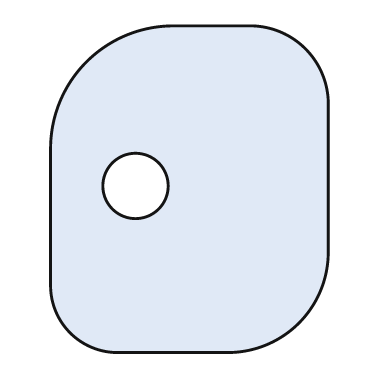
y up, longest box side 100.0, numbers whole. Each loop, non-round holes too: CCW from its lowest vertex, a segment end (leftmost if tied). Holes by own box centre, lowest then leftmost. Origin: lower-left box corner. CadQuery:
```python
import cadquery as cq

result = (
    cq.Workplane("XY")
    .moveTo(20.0, 0.0)
    .lineTo(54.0, 0.0)
    .threePointArc((76.0, 9.0), (85.0, 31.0))
    .lineTo(85.0, 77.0)
    .threePointArc((78.0, 93.0), (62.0, 100.0))
    .lineTo(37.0, 100.0)
    .threePointArc((11.0, 89.0), (0.0, 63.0))
    .lineTo(0.0, 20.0)
    .threePointArc((6.0, 6.0), (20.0, 0.0))
    .close()
    .moveTo(26.0, 51.0)
    .circle(10.0)
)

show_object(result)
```